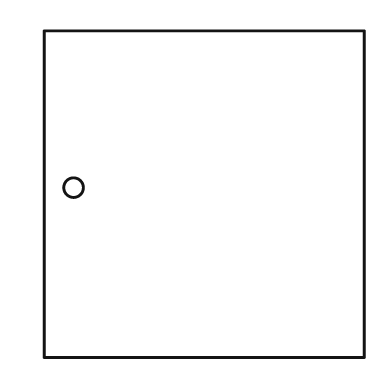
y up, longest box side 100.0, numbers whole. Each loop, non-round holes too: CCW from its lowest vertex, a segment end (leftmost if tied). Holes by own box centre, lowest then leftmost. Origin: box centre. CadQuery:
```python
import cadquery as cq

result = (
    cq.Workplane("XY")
    .moveTo(-49.0, -50.0)
    .lineTo(49.0, -50.0)
    .lineTo(49.0, 50.0)
    .lineTo(-49.0, 50.0)
    .close()
    .moveTo(-40.0, 2.0)
    .circle(3.0)
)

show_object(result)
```